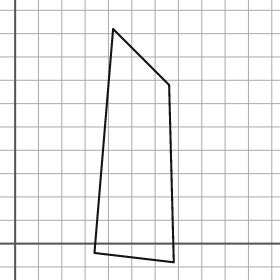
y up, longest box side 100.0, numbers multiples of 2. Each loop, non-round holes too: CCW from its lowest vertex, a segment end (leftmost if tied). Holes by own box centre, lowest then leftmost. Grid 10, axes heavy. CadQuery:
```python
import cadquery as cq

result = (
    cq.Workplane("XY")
    .moveTo(68.0, -8.0)
    .lineTo(66.0, 68.0)
    .lineTo(42.0, 92.0)
    .lineTo(34.0, -4.0)
    .close()
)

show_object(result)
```